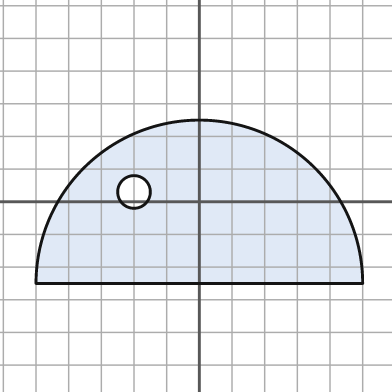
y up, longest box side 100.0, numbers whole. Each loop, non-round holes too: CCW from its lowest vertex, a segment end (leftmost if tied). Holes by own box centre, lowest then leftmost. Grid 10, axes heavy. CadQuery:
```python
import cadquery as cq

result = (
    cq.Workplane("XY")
    .moveTo(-50.0, -25.0)
    .lineTo(50.0, -25.0)
    .threePointArc((0.0, 25.0), (-50.0, -25.0))
    .close()
    .moveTo(-20.0, 3.0)
    .circle(5.0)
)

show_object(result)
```